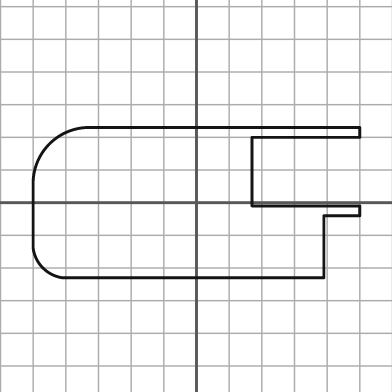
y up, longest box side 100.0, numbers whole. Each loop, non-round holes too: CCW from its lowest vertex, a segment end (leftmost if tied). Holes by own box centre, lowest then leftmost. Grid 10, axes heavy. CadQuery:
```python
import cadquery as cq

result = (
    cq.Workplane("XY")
    .moveTo(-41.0, -23.0)
    .lineTo(39.0, -23.0)
    .lineTo(39.0, -4.0)
    .lineTo(50.0, -4.0)
    .lineTo(50.0, -1.0)
    .lineTo(17.0, -1.0)
    .lineTo(17.0, 20.0)
    .lineTo(50.0, 20.0)
    .lineTo(50.0, 23.0)
    .lineTo(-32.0, 23.0)
    .threePointArc((-45.0, 18.0), (-50.0, 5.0))
    .lineTo(-50.0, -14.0)
    .threePointArc((-47.0, -20.0), (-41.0, -23.0))
    .close()
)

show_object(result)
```